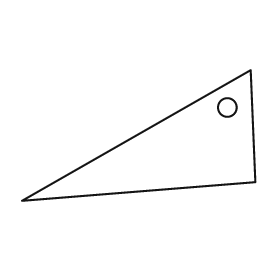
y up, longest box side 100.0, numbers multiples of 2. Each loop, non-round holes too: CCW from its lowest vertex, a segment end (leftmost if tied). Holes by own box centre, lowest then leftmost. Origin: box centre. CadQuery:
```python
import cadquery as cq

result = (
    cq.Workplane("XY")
    .moveTo(-50.0, -28.0)
    .lineTo(50.0, -20.0)
    .lineTo(48.0, 28.0)
    .close()
    .moveTo(38.0, 12.0)
    .circle(4.0)
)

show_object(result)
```